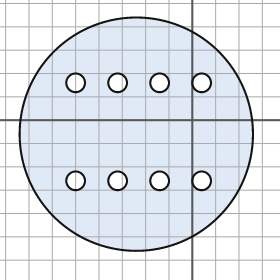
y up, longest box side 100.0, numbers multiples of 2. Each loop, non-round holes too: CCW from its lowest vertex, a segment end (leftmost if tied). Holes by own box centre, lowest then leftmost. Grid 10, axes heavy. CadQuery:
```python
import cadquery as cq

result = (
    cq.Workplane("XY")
    .moveTo(-24.0, -6.0)
    .circle(50.0)
    .moveTo(-50.0, -26.0)
    .circle(4.0)
    .moveTo(-32.0, -26.0)
    .circle(4.0)
    .moveTo(-14.0, -26.0)
    .circle(4.0)
    .moveTo(4.0, -26.0)
    .circle(4.0)
    .moveTo(-50.0, 16.0)
    .circle(4.0)
    .moveTo(-32.0, 16.0)
    .circle(4.0)
    .moveTo(-14.0, 16.0)
    .circle(4.0)
    .moveTo(4.0, 16.0)
    .circle(4.0)
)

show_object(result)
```